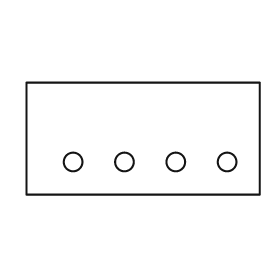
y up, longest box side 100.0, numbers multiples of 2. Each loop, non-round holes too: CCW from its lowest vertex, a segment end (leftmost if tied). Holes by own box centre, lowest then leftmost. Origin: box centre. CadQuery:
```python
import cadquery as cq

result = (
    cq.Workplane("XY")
    .moveTo(-50.0, -24.0)
    .lineTo(50.0, -24.0)
    .lineTo(50.0, 24.0)
    .lineTo(-50.0, 24.0)
    .close()
    .moveTo(-30.0, -10.0)
    .circle(4.0)
    .moveTo(-8.0, -10.0)
    .circle(4.0)
    .moveTo(14.0, -10.0)
    .circle(4.0)
    .moveTo(36.0, -10.0)
    .circle(4.0)
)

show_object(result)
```